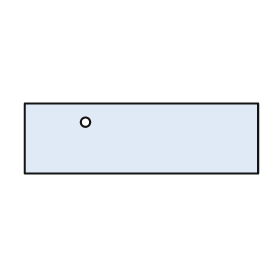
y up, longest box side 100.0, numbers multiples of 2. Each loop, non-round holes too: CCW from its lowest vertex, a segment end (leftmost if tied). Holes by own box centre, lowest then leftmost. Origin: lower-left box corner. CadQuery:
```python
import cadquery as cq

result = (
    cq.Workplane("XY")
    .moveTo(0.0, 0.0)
    .lineTo(100.0, 0.0)
    .lineTo(100.0, 30.0)
    .lineTo(0.0, 30.0)
    .close()
    .moveTo(26.0, 22.0)
    .circle(2.0)
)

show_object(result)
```